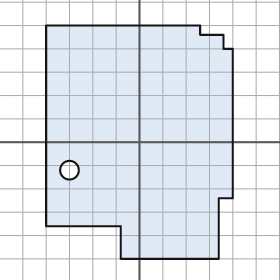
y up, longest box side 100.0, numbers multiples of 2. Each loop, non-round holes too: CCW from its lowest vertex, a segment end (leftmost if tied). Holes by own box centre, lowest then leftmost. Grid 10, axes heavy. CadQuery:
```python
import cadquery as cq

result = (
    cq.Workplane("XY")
    .moveTo(-8.0, -50.0)
    .lineTo(34.0, -50.0)
    .lineTo(34.0, -24.0)
    .lineTo(40.0, -24.0)
    .lineTo(40.0, 40.0)
    .lineTo(36.0, 40.0)
    .lineTo(36.0, 46.0)
    .lineTo(26.0, 46.0)
    .lineTo(26.0, 50.0)
    .lineTo(-40.0, 50.0)
    .lineTo(-40.0, -36.0)
    .lineTo(-8.0, -36.0)
    .close()
    .moveTo(-30.0, -12.0)
    .circle(4.0)
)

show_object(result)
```